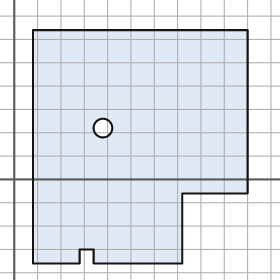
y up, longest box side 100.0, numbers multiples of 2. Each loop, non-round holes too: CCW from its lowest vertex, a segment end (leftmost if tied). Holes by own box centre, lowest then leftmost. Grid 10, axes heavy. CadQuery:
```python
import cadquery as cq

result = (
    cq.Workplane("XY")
    .moveTo(8.0, -36.0)
    .lineTo(28.0, -36.0)
    .lineTo(28.0, -30.0)
    .lineTo(34.0, -30.0)
    .lineTo(34.0, -36.0)
    .lineTo(72.0, -36.0)
    .lineTo(72.0, -6.0)
    .lineTo(100.0, -6.0)
    .lineTo(100.0, 64.0)
    .lineTo(8.0, 64.0)
    .close()
    .moveTo(38.0, 22.0)
    .circle(4.0)
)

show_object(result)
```